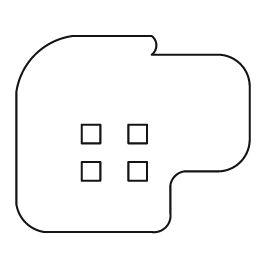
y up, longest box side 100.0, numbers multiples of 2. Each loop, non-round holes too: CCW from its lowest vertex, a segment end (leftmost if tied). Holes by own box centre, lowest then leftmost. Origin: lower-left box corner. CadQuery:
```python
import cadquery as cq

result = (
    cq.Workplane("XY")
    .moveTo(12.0, 0.0)
    .lineTo(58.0, 0.0)
    .threePointArc((64.0, 2.0), (66.0, 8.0))
    .lineTo(66.0, 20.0)
    .threePointArc((68.0, 24.0), (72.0, 26.0))
    .lineTo(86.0, 26.0)
    .threePointArc((96.0, 30.0), (100.0, 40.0))
    .lineTo(100.0, 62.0)
    .threePointArc((96.0, 72.0), (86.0, 76.0))
    .lineTo(58.0, 76.0)
    .threePointArc((60.0, 80.0), (58.0, 84.0))
    .lineTo(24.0, 84.0)
    .threePointArc((8.0, 76.0), (0.0, 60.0))
    .lineTo(0.0, 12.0)
    .threePointArc((4.0, 4.0), (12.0, 0.0))
    .close()
    .moveTo(28.0, 22.0)
    .lineTo(36.0, 22.0)
    .lineTo(36.0, 30.0)
    .lineTo(28.0, 30.0)
    .close()
    .moveTo(48.0, 22.0)
    .lineTo(56.0, 22.0)
    .lineTo(56.0, 30.0)
    .lineTo(48.0, 30.0)
    .close()
    .moveTo(28.0, 38.0)
    .lineTo(36.0, 38.0)
    .lineTo(36.0, 46.0)
    .lineTo(28.0, 46.0)
    .close()
    .moveTo(48.0, 38.0)
    .lineTo(56.0, 38.0)
    .lineTo(56.0, 46.0)
    .lineTo(48.0, 46.0)
    .close()
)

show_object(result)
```